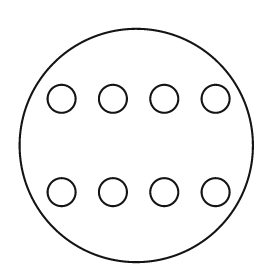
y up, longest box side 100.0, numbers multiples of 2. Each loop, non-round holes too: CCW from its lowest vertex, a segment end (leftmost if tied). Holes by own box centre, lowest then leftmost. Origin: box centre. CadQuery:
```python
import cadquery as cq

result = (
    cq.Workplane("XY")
    .moveTo(0.0, 0.0)
    .circle(50.0)
    .moveTo(-32.0, -20.0)
    .circle(6.0)
    .moveTo(-10.0, -20.0)
    .circle(6.0)
    .moveTo(12.0, -20.0)
    .circle(6.0)
    .moveTo(34.0, -20.0)
    .circle(6.0)
    .moveTo(-32.0, 20.0)
    .circle(6.0)
    .moveTo(-10.0, 20.0)
    .circle(6.0)
    .moveTo(12.0, 20.0)
    .circle(6.0)
    .moveTo(34.0, 20.0)
    .circle(6.0)
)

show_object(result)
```